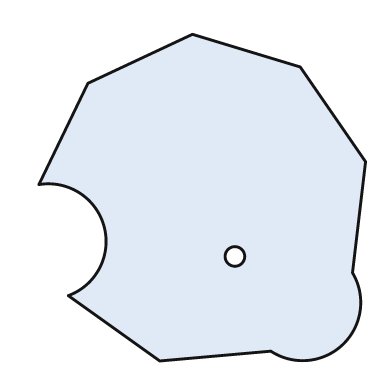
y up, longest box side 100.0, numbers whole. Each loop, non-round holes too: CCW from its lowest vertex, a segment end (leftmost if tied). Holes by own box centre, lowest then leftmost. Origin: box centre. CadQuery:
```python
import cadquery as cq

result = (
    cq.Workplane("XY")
    .moveTo(-13.0, -50.0)
    .lineTo(21.0, -47.0)
    .threePointArc((43.0, -45.0), (46.0, -23.0))
    .lineTo(50.0, 11.0)
    .lineTo(30.0, 40.0)
    .lineTo(-3.0, 50.0)
    .lineTo(-35.0, 35.0)
    .lineTo(-50.0, 4.0)
    .threePointArc((-30.0, -9.0), (-41.0, -30.0))
    .close()
    .moveTo(10.0, -18.0)
    .circle(3.0)
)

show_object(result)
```